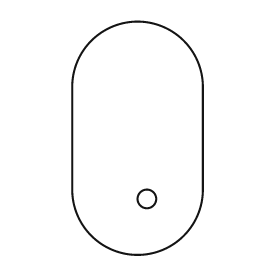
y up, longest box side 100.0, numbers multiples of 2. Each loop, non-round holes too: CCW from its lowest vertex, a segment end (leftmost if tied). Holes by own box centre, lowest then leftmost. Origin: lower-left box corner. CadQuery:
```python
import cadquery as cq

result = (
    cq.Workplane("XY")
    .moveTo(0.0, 28.0)
    .threePointArc((28.0, 0.0), (56.0, 28.0))
    .lineTo(56.0, 72.0)
    .threePointArc((28.0, 100.0), (0.0, 72.0))
    .close()
    .moveTo(32.0, 24.0)
    .circle(4.0)
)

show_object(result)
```